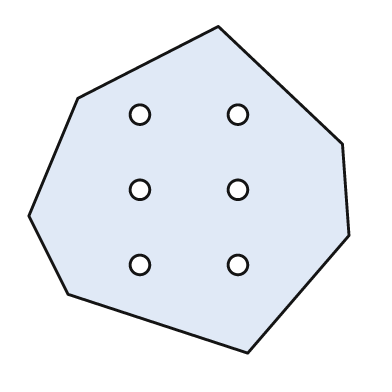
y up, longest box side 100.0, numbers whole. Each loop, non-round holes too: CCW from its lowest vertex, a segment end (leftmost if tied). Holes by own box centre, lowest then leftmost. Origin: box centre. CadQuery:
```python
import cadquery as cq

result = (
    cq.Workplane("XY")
    .moveTo(18.0, -50.0)
    .lineTo(49.0, -14.0)
    .lineTo(47.0, 14.0)
    .lineTo(9.0, 50.0)
    .lineTo(-34.0, 28.0)
    .lineTo(-49.0, -8.0)
    .lineTo(-37.0, -32.0)
    .close()
    .moveTo(-15.0, -23.0)
    .circle(3.0)
    .moveTo(15.0, -23.0)
    .circle(3.0)
    .moveTo(-15.0, 0.0)
    .circle(3.0)
    .moveTo(15.0, 0.0)
    .circle(3.0)
    .moveTo(-15.0, 23.0)
    .circle(3.0)
    .moveTo(15.0, 23.0)
    .circle(3.0)
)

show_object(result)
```